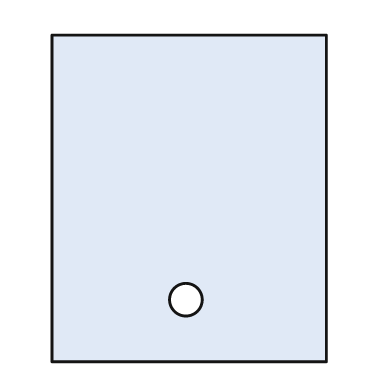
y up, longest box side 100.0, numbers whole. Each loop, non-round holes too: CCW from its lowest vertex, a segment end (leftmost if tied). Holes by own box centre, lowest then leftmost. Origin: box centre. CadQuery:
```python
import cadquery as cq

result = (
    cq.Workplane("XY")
    .moveTo(-42.0, -50.0)
    .lineTo(42.0, -50.0)
    .lineTo(42.0, 50.0)
    .lineTo(-42.0, 50.0)
    .close()
    .moveTo(-1.0, -31.0)
    .circle(5.0)
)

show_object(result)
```